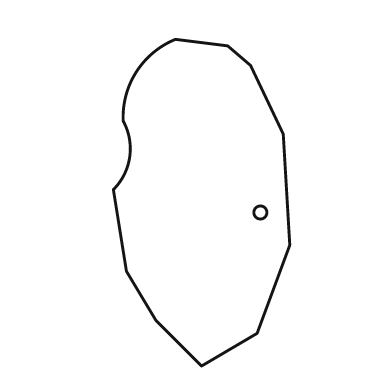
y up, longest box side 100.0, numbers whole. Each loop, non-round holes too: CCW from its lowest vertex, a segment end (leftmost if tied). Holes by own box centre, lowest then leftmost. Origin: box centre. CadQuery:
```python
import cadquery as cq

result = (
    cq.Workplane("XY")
    .moveTo(0.0, -50.0)
    .lineTo(17.0, -40.0)
    .lineTo(27.0, -13.0)
    .lineTo(25.0, 21.0)
    .lineTo(15.0, 42.0)
    .lineTo(8.0, 48.0)
    .lineTo(-8.0, 50.0)
    .threePointArc((-20.0, 40.0), (-24.0, 25.0))
    .threePointArc((-22.0, 14.0), (-27.0, 4.0))
    .lineTo(-23.0, -21.0)
    .lineTo(-14.0, -36.0)
    .close()
    .moveTo(18.0, -3.0)
    .circle(2.0)
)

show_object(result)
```